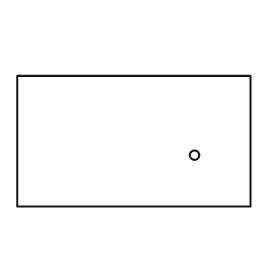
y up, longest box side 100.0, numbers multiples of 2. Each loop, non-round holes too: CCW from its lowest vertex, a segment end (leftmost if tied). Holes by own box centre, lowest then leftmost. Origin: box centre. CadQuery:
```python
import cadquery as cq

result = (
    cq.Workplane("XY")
    .moveTo(-50.0, -28.0)
    .lineTo(50.0, -28.0)
    .lineTo(50.0, 28.0)
    .lineTo(-50.0, 28.0)
    .close()
    .moveTo(26.0, -6.0)
    .circle(2.0)
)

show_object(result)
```